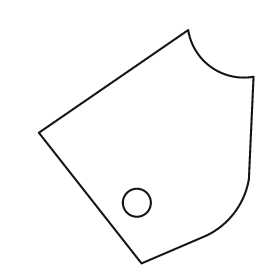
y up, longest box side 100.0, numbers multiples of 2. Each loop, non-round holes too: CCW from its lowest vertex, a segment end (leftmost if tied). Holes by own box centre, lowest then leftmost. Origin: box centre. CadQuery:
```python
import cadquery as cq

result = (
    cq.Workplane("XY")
    .moveTo(-2.0, -50.0)
    .lineTo(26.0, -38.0)
    .threePointArc((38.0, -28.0), (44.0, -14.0))
    .lineTo(46.0, 30.0)
    .threePointArc((28.0, 34.0), (18.0, 50.0))
    .lineTo(-46.0, 6.0)
    .close()
    .moveTo(-4.0, -24.0)
    .circle(6.0)
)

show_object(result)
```